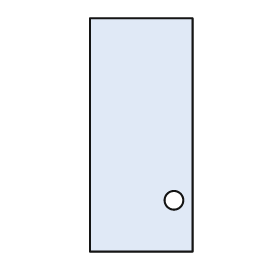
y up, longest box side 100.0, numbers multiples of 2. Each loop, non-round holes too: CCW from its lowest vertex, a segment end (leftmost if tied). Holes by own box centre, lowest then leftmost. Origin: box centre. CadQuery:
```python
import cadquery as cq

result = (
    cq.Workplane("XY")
    .moveTo(-22.0, -50.0)
    .lineTo(22.0, -50.0)
    .lineTo(22.0, 50.0)
    .lineTo(-22.0, 50.0)
    .close()
    .moveTo(14.0, -28.0)
    .circle(4.0)
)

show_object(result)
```